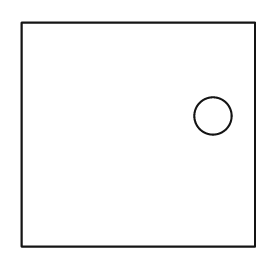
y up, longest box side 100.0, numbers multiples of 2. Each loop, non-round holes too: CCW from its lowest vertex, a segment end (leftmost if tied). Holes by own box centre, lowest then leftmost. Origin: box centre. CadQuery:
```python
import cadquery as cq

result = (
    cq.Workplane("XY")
    .moveTo(-50.0, -48.0)
    .lineTo(50.0, -48.0)
    .lineTo(50.0, 48.0)
    .lineTo(-50.0, 48.0)
    .close()
    .moveTo(32.0, 8.0)
    .circle(8.0)
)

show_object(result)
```